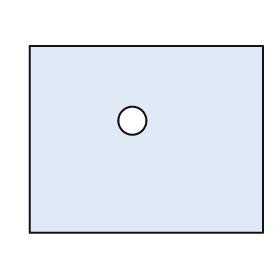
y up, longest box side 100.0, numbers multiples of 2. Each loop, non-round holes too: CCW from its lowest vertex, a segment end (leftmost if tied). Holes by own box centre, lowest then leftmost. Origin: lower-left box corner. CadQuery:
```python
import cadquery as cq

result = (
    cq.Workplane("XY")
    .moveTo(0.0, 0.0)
    .lineTo(100.0, 0.0)
    .lineTo(100.0, 80.0)
    .lineTo(0.0, 80.0)
    .close()
    .moveTo(44.0, 48.0)
    .circle(6.0)
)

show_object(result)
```